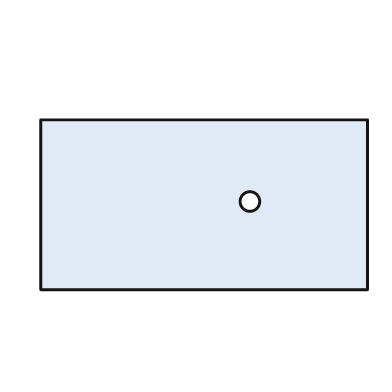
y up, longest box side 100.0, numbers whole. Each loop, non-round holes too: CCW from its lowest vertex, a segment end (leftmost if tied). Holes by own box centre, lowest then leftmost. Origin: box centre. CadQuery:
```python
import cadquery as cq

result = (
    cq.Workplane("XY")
    .moveTo(-50.0, -26.0)
    .lineTo(50.0, -26.0)
    .lineTo(50.0, 26.0)
    .lineTo(-50.0, 26.0)
    .close()
    .moveTo(14.0, 1.0)
    .circle(3.0)
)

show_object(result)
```